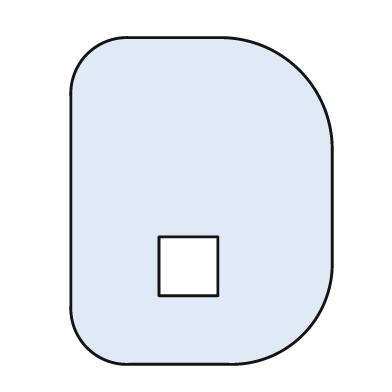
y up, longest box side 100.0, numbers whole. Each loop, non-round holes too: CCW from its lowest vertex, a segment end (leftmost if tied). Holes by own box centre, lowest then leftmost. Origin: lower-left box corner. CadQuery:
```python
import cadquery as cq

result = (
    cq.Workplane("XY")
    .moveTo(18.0, 0.0)
    .lineTo(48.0, 0.0)
    .threePointArc((71.0, 9.0), (80.0, 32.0))
    .lineTo(80.0, 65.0)
    .threePointArc((70.0, 90.0), (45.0, 100.0))
    .lineTo(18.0, 100.0)
    .threePointArc((5.0, 95.0), (0.0, 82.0))
    .lineTo(0.0, 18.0)
    .threePointArc((5.0, 5.0), (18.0, 0.0))
    .close()
    .moveTo(27.0, 21.0)
    .lineTo(45.0, 21.0)
    .lineTo(45.0, 39.0)
    .lineTo(27.0, 39.0)
    .close()
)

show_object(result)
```